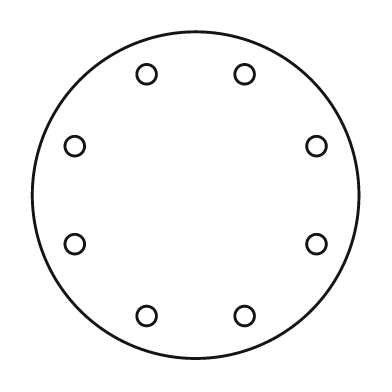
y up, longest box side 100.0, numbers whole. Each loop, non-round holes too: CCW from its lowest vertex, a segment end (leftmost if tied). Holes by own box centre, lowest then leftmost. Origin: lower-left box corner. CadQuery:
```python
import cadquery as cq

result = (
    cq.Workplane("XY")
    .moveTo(50.0, 50.0)
    .circle(50.0)
    .moveTo(35.0, 13.0)
    .circle(3.0)
    .moveTo(65.0, 13.0)
    .circle(3.0)
    .moveTo(13.0, 35.0)
    .circle(3.0)
    .moveTo(87.0, 35.0)
    .circle(3.0)
    .moveTo(13.0, 65.0)
    .circle(3.0)
    .moveTo(87.0, 65.0)
    .circle(3.0)
    .moveTo(35.0, 87.0)
    .circle(3.0)
    .moveTo(65.0, 87.0)
    .circle(3.0)
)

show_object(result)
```